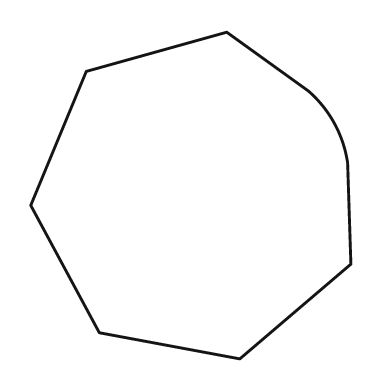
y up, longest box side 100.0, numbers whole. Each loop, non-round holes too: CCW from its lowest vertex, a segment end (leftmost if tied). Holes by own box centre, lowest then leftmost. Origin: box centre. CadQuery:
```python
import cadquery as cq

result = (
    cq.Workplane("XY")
    .moveTo(15.0, -50.0)
    .lineTo(49.0, -21.0)
    .lineTo(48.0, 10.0)
    .threePointArc((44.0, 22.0), (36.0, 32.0))
    .lineTo(11.0, 50.0)
    .lineTo(-32.0, 38.0)
    .lineTo(-49.0, -3.0)
    .lineTo(-28.0, -42.0)
    .close()
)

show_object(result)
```